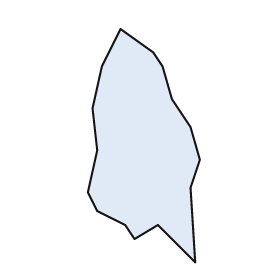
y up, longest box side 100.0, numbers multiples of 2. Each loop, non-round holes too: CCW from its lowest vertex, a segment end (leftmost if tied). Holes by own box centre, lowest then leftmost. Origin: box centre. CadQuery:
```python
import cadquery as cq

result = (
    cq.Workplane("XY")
    .moveTo(22.0, -50.0)
    .lineTo(20.0, -18.0)
    .lineTo(24.0, -6.0)
    .lineTo(20.0, 8.0)
    .lineTo(12.0, 20.0)
    .lineTo(8.0, 34.0)
    .lineTo(4.0, 40.0)
    .lineTo(-10.0, 50.0)
    .lineTo(-18.0, 34.0)
    .lineTo(-22.0, 16.0)
    .lineTo(-20.0, -2.0)
    .lineTo(-24.0, -20.0)
    .lineTo(-20.0, -28.0)
    .lineTo(-8.0, -34.0)
    .lineTo(-4.0, -40.0)
    .lineTo(6.0, -34.0)
    .close()
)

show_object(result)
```